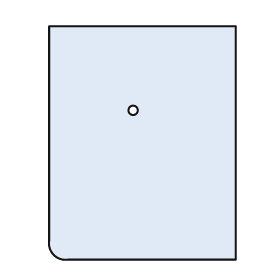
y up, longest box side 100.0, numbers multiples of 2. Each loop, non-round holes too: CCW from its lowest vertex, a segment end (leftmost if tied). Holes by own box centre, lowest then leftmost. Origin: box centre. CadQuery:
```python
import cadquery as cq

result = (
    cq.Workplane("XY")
    .moveTo(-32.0, -50.0)
    .lineTo(40.0, -50.0)
    .lineTo(40.0, 50.0)
    .lineTo(-40.0, 50.0)
    .lineTo(-40.0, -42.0)
    .threePointArc((-38.0, -48.0), (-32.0, -50.0))
    .close()
    .moveTo(-4.0, 14.0)
    .circle(2.0)
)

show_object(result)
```